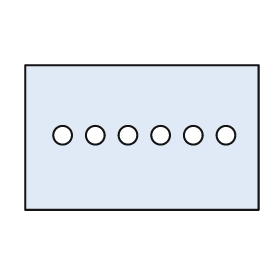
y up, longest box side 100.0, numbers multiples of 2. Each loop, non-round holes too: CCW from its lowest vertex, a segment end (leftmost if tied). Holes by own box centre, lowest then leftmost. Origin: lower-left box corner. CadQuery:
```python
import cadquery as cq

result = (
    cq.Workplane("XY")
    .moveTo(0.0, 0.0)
    .lineTo(100.0, 0.0)
    .lineTo(100.0, 62.0)
    .lineTo(0.0, 62.0)
    .close()
    .moveTo(16.0, 32.0)
    .circle(4.0)
    .moveTo(30.0, 32.0)
    .circle(4.0)
    .moveTo(44.0, 32.0)
    .circle(4.0)
    .moveTo(58.0, 32.0)
    .circle(4.0)
    .moveTo(72.0, 32.0)
    .circle(4.0)
    .moveTo(86.0, 32.0)
    .circle(4.0)
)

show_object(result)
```